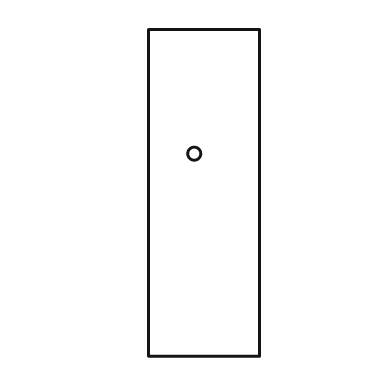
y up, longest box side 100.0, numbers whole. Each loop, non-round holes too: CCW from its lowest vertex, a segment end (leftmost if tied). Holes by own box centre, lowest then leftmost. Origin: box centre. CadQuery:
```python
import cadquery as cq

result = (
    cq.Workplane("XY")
    .moveTo(-17.0, -50.0)
    .lineTo(17.0, -50.0)
    .lineTo(17.0, 50.0)
    .lineTo(-17.0, 50.0)
    .close()
    .moveTo(-3.0, 12.0)
    .circle(2.0)
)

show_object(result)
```